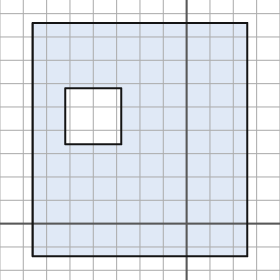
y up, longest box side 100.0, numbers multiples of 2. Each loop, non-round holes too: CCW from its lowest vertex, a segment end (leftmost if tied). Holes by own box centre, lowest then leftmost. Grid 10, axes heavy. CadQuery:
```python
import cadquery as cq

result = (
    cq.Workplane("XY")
    .moveTo(-66.0, -14.0)
    .lineTo(26.0, -14.0)
    .lineTo(26.0, 86.0)
    .lineTo(-66.0, 86.0)
    .close()
    .moveTo(-52.0, 34.0)
    .lineTo(-28.0, 34.0)
    .lineTo(-28.0, 58.0)
    .lineTo(-52.0, 58.0)
    .close()
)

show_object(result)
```